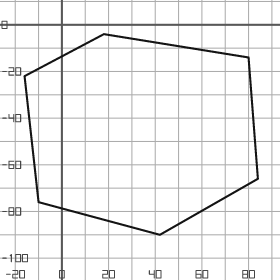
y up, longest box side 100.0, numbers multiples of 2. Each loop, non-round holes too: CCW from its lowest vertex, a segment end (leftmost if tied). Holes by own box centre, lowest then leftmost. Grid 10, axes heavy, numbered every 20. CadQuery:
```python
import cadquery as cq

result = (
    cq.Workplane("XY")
    .moveTo(42.0, -90.0)
    .lineTo(84.0, -66.0)
    .lineTo(80.0, -14.0)
    .lineTo(18.0, -4.0)
    .lineTo(-16.0, -22.0)
    .lineTo(-10.0, -76.0)
    .close()
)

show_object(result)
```